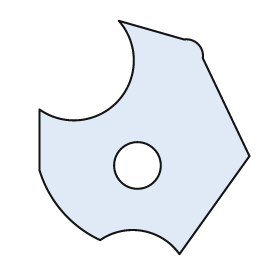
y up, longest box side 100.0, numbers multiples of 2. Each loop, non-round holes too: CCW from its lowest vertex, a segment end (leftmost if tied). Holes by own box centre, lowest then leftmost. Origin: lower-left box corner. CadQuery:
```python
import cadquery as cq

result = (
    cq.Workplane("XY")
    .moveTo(60.0, 0.0)
    .lineTo(90.0, 42.0)
    .lineTo(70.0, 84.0)
    .threePointArc((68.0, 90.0), (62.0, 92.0))
    .lineTo(34.0, 100.0)
    .threePointArc((34.0, 66.0), (0.0, 62.0))
    .lineTo(0.0, 36.0)
    .threePointArc((10.0, 18.0), (26.0, 6.0))
    .threePointArc((44.0, 10.0), (60.0, 0.0))
    .close()
    .moveTo(42.0, 38.0)
    .circle(10.0)
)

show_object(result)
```